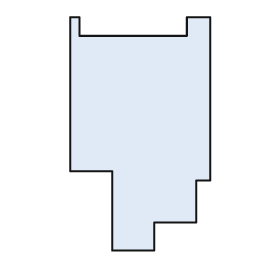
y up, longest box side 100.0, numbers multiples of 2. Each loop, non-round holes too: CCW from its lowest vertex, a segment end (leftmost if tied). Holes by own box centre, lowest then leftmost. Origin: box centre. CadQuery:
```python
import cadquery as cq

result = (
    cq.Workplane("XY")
    .moveTo(-12.0, -50.0)
    .lineTo(6.0, -50.0)
    .lineTo(6.0, -38.0)
    .lineTo(24.0, -38.0)
    .lineTo(24.0, -20.0)
    .lineTo(30.0, -20.0)
    .lineTo(30.0, 50.0)
    .lineTo(20.0, 50.0)
    .lineTo(20.0, 42.0)
    .lineTo(-26.0, 42.0)
    .lineTo(-26.0, 50.0)
    .lineTo(-30.0, 50.0)
    .lineTo(-30.0, -16.0)
    .lineTo(-12.0, -16.0)
    .close()
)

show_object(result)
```